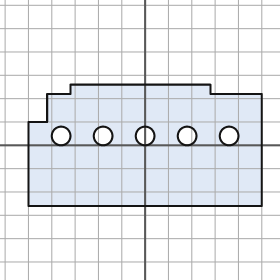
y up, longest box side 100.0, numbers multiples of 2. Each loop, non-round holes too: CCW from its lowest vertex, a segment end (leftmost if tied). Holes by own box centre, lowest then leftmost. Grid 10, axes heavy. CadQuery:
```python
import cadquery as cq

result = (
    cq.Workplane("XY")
    .moveTo(-50.0, -26.0)
    .lineTo(50.0, -26.0)
    .lineTo(50.0, 22.0)
    .lineTo(28.0, 22.0)
    .lineTo(28.0, 26.0)
    .lineTo(-32.0, 26.0)
    .lineTo(-32.0, 22.0)
    .lineTo(-42.0, 22.0)
    .lineTo(-42.0, 10.0)
    .lineTo(-50.0, 10.0)
    .close()
    .moveTo(-36.0, 4.0)
    .circle(4.0)
    .moveTo(-18.0, 4.0)
    .circle(4.0)
    .moveTo(0.0, 4.0)
    .circle(4.0)
    .moveTo(18.0, 4.0)
    .circle(4.0)
    .moveTo(36.0, 4.0)
    .circle(4.0)
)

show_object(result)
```